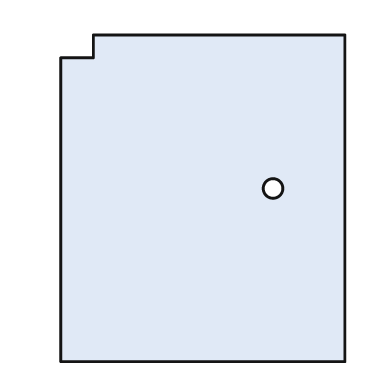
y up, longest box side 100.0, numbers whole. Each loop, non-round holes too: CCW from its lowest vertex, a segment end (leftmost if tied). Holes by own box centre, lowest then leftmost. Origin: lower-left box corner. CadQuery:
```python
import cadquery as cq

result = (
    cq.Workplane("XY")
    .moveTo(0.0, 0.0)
    .lineTo(87.0, 0.0)
    .lineTo(87.0, 100.0)
    .lineTo(10.0, 100.0)
    .lineTo(10.0, 93.0)
    .lineTo(0.0, 93.0)
    .close()
    .moveTo(65.0, 53.0)
    .circle(3.0)
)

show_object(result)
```